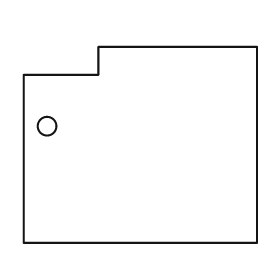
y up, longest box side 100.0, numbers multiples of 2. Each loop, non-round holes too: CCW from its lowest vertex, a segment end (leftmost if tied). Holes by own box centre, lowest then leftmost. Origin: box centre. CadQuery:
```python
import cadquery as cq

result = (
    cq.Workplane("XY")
    .moveTo(-50.0, -42.0)
    .lineTo(50.0, -42.0)
    .lineTo(50.0, 42.0)
    .lineTo(-18.0, 42.0)
    .lineTo(-18.0, 30.0)
    .lineTo(-50.0, 30.0)
    .close()
    .moveTo(-40.0, 8.0)
    .circle(4.0)
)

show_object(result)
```